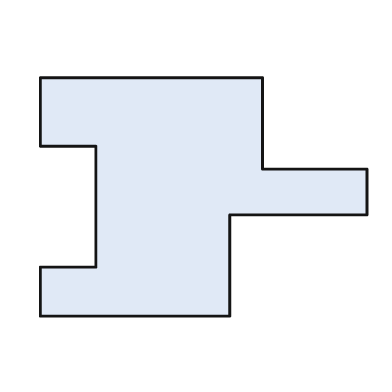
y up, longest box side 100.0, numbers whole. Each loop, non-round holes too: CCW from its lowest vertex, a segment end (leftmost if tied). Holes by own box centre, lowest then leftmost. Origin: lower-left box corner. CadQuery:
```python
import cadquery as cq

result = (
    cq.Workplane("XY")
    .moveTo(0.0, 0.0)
    .lineTo(58.0, 0.0)
    .lineTo(58.0, 31.0)
    .lineTo(100.0, 31.0)
    .lineTo(100.0, 45.0)
    .lineTo(68.0, 45.0)
    .lineTo(68.0, 73.0)
    .lineTo(0.0, 73.0)
    .lineTo(0.0, 52.0)
    .lineTo(17.0, 52.0)
    .lineTo(17.0, 15.0)
    .lineTo(0.0, 15.0)
    .close()
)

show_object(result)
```